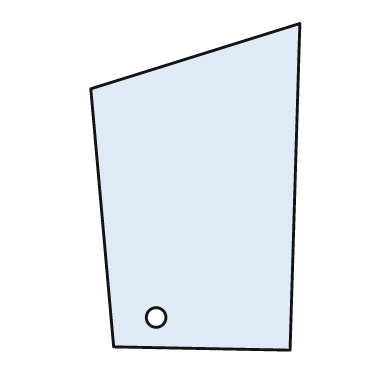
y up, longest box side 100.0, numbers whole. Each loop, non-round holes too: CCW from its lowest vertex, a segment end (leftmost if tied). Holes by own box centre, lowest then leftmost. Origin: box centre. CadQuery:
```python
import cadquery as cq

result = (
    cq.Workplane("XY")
    .moveTo(29.0, -50.0)
    .lineTo(32.0, 50.0)
    .lineTo(-32.0, 30.0)
    .lineTo(-25.0, -49.0)
    .close()
    .moveTo(-12.0, -40.0)
    .circle(3.0)
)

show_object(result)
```